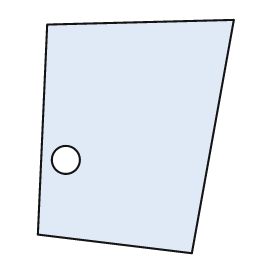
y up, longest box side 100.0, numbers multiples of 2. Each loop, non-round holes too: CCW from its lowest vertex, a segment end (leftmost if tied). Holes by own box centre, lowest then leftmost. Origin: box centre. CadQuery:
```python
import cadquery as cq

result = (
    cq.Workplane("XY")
    .moveTo(24.0, -50.0)
    .lineTo(42.0, 50.0)
    .lineTo(-38.0, 48.0)
    .lineTo(-42.0, -42.0)
    .close()
    .moveTo(-30.0, -10.0)
    .circle(6.0)
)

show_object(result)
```